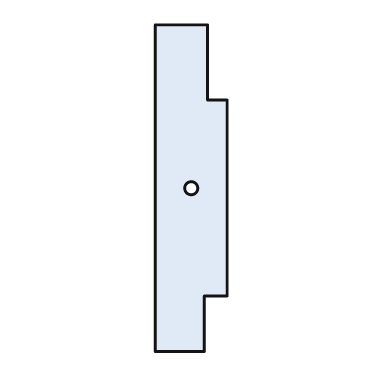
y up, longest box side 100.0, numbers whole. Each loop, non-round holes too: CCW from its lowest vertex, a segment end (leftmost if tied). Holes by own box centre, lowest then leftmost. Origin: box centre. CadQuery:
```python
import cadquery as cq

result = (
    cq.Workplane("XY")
    .moveTo(-11.0, -50.0)
    .lineTo(4.0, -50.0)
    .lineTo(4.0, -33.0)
    .lineTo(11.0, -33.0)
    .lineTo(11.0, 27.0)
    .lineTo(5.0, 27.0)
    .lineTo(5.0, 50.0)
    .lineTo(-11.0, 50.0)
    .close()
    .moveTo(0.0, 0.0)
    .circle(2.0)
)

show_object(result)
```